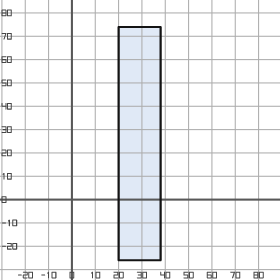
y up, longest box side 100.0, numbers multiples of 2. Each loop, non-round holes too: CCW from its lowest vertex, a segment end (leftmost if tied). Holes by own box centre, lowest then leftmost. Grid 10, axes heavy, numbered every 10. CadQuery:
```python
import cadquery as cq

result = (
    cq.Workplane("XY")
    .moveTo(20.0, -26.0)
    .lineTo(38.0, -26.0)
    .lineTo(38.0, 74.0)
    .lineTo(20.0, 74.0)
    .close()
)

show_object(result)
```